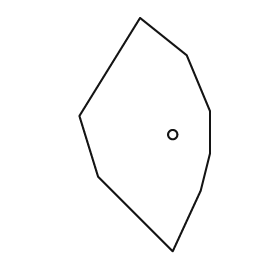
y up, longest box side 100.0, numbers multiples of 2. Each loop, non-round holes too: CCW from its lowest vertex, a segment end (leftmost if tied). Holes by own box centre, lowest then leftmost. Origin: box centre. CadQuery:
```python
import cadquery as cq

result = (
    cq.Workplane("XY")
    .moveTo(12.0, -50.0)
    .lineTo(24.0, -24.0)
    .lineTo(28.0, -8.0)
    .lineTo(28.0, 10.0)
    .lineTo(18.0, 34.0)
    .lineTo(-2.0, 50.0)
    .lineTo(-28.0, 8.0)
    .lineTo(-20.0, -18.0)
    .close()
    .moveTo(12.0, 0.0)
    .circle(2.0)
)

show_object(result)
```